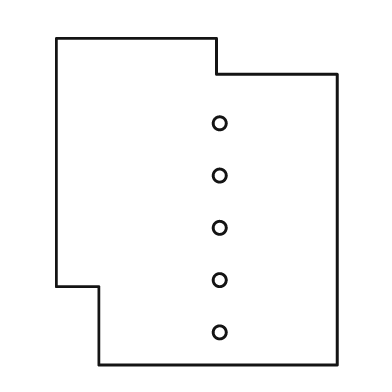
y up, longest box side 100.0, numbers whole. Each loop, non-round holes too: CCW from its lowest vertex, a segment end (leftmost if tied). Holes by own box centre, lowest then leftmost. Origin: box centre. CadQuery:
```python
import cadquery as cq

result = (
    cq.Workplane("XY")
    .moveTo(-30.0, -50.0)
    .lineTo(43.0, -50.0)
    .lineTo(43.0, 39.0)
    .lineTo(6.0, 39.0)
    .lineTo(6.0, 50.0)
    .lineTo(-43.0, 50.0)
    .lineTo(-43.0, -26.0)
    .lineTo(-30.0, -26.0)
    .close()
    .moveTo(7.0, -40.0)
    .circle(2.0)
    .moveTo(7.0, -24.0)
    .circle(2.0)
    .moveTo(7.0, -8.0)
    .circle(2.0)
    .moveTo(7.0, 8.0)
    .circle(2.0)
    .moveTo(7.0, 24.0)
    .circle(2.0)
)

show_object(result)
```